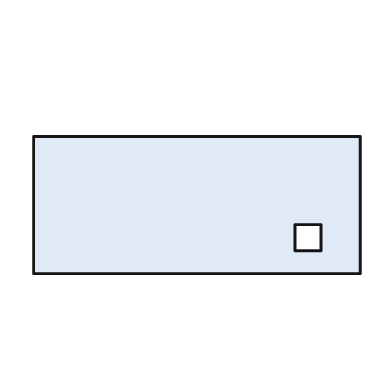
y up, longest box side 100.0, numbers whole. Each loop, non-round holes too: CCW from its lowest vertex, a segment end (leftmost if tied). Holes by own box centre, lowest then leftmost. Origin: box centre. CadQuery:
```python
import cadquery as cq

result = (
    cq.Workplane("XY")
    .moveTo(-50.0, -21.0)
    .lineTo(50.0, -21.0)
    .lineTo(50.0, 21.0)
    .lineTo(-50.0, 21.0)
    .close()
    .moveTo(30.0, -14.0)
    .lineTo(38.0, -14.0)
    .lineTo(38.0, -6.0)
    .lineTo(30.0, -6.0)
    .close()
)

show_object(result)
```